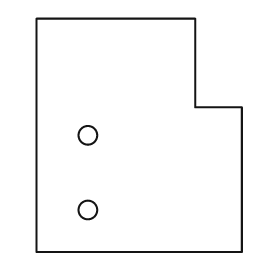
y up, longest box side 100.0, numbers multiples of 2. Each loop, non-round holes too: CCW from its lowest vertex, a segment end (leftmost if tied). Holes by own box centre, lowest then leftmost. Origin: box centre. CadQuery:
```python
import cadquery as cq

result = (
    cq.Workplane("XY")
    .moveTo(-44.0, -50.0)
    .lineTo(44.0, -50.0)
    .lineTo(44.0, 12.0)
    .lineTo(24.0, 12.0)
    .lineTo(24.0, 50.0)
    .lineTo(-44.0, 50.0)
    .close()
    .moveTo(-22.0, -32.0)
    .circle(4.0)
    .moveTo(-22.0, 0.0)
    .circle(4.0)
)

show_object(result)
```